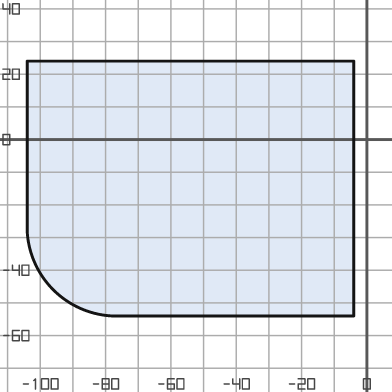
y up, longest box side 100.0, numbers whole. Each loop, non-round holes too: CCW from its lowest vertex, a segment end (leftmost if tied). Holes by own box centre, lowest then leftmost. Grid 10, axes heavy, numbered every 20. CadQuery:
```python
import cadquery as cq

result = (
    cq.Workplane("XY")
    .moveTo(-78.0, -54.0)
    .lineTo(-4.0, -54.0)
    .lineTo(-4.0, 24.0)
    .lineTo(-104.0, 24.0)
    .lineTo(-104.0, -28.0)
    .threePointArc((-96.0, -46.0), (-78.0, -54.0))
    .close()
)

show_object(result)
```